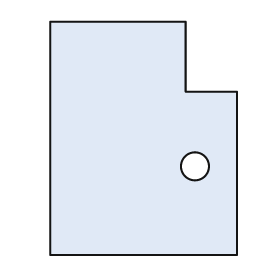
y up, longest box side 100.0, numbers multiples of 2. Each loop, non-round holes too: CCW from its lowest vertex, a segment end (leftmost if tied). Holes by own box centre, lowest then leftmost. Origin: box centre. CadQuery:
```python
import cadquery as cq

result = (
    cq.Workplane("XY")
    .moveTo(-40.0, -50.0)
    .lineTo(40.0, -50.0)
    .lineTo(40.0, 20.0)
    .lineTo(18.0, 20.0)
    .lineTo(18.0, 50.0)
    .lineTo(-40.0, 50.0)
    .close()
    .moveTo(22.0, -12.0)
    .circle(6.0)
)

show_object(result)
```